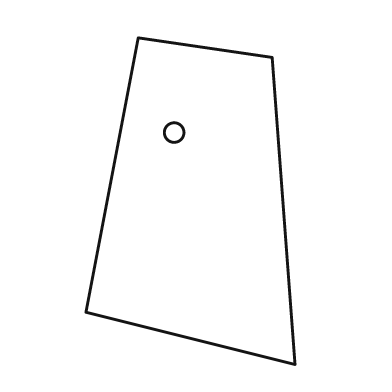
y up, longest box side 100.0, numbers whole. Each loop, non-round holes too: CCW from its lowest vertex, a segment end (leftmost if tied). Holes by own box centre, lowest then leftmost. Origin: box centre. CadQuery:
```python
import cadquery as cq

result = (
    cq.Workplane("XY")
    .moveTo(32.0, -50.0)
    .lineTo(25.0, 44.0)
    .lineTo(-16.0, 50.0)
    .lineTo(-32.0, -34.0)
    .close()
    .moveTo(-5.0, 21.0)
    .circle(3.0)
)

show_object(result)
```